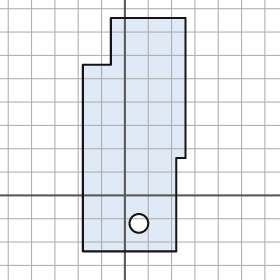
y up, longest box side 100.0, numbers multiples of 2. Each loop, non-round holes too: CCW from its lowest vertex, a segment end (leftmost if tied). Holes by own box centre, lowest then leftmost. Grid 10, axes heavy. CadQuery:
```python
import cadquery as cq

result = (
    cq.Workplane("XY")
    .moveTo(-18.0, -24.0)
    .lineTo(22.0, -24.0)
    .lineTo(22.0, 16.0)
    .lineTo(26.0, 16.0)
    .lineTo(26.0, 76.0)
    .lineTo(-6.0, 76.0)
    .lineTo(-6.0, 56.0)
    .lineTo(-18.0, 56.0)
    .close()
    .moveTo(6.0, -12.0)
    .circle(4.0)
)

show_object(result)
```